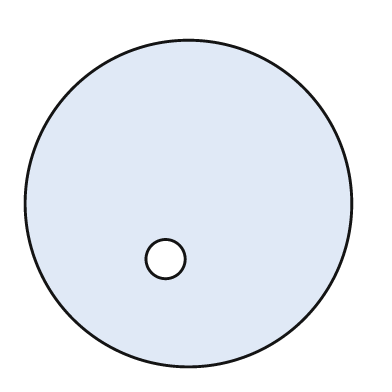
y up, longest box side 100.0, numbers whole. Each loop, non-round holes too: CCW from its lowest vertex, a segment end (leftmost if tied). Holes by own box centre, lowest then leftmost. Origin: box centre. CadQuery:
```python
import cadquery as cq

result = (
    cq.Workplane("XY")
    .moveTo(0.0, 0.0)
    .circle(50.0)
    .moveTo(-7.0, -17.0)
    .circle(6.0)
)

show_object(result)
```